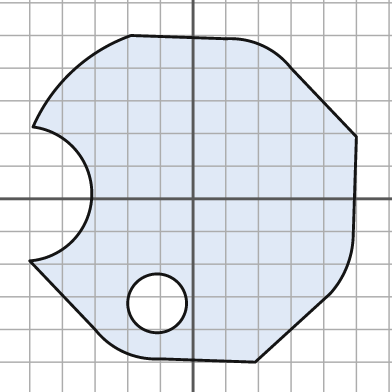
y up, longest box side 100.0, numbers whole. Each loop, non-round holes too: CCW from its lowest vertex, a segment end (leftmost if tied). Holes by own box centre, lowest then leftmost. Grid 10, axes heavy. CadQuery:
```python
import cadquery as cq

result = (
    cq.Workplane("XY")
    .moveTo(19.0, -50.0)
    .lineTo(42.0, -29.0)
    .threePointArc((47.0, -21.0), (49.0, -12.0))
    .lineTo(50.0, 19.0)
    .lineTo(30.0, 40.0)
    .threePointArc((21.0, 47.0), (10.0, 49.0))
    .lineTo(-19.0, 50.0)
    .threePointArc((-37.0, 39.0), (-49.0, 22.0))
    .threePointArc((-31.0, 1.0), (-50.0, -19.0))
    .lineTo(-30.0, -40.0)
    .threePointArc((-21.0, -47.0), (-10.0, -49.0))
    .close()
    .moveTo(-11.0, -32.0)
    .circle(9.0)
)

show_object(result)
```